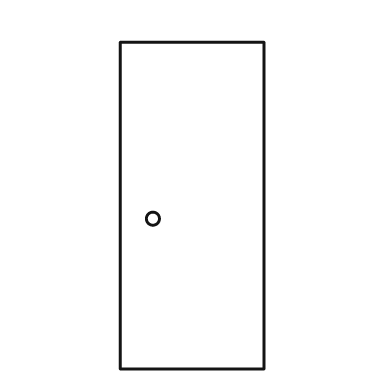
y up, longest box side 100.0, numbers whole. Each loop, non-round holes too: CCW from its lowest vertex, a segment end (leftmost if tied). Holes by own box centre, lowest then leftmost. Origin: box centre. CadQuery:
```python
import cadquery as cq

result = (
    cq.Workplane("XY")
    .moveTo(-22.0, -50.0)
    .lineTo(22.0, -50.0)
    .lineTo(22.0, 50.0)
    .lineTo(-22.0, 50.0)
    .close()
    .moveTo(-12.0, -4.0)
    .circle(2.0)
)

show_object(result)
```